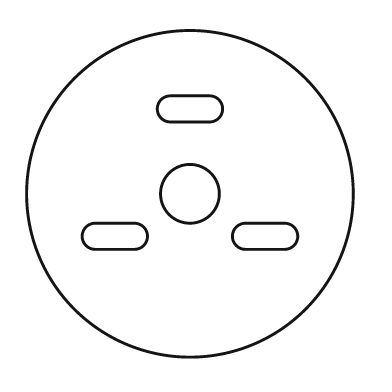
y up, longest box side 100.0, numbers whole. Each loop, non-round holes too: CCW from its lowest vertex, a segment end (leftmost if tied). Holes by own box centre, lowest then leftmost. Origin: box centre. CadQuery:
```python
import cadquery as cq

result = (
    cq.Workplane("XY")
    .moveTo(0.0, 0.0)
    .circle(50.0)
    .moveTo(-29.0, -17.0)
    .lineTo(-17.0, -17.0)
    .threePointArc((-13.0, -13.0), (-17.0, -9.0))
    .lineTo(-29.0, -9.0)
    .threePointArc((-33.0, -13.0), (-29.0, -17.0))
    .close()
    .moveTo(17.0, -17.0)
    .lineTo(29.0, -17.0)
    .threePointArc((33.0, -13.0), (29.0, -9.0))
    .lineTo(17.0, -9.0)
    .threePointArc((13.0, -13.0), (17.0, -17.0))
    .close()
    .moveTo(0.0, 0.0)
    .circle(9.0)
    .moveTo(-6.0, 22.0)
    .lineTo(6.0, 22.0)
    .threePointArc((10.0, 26.0), (6.0, 30.0))
    .lineTo(-6.0, 30.0)
    .threePointArc((-10.0, 26.0), (-6.0, 22.0))
    .close()
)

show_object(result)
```